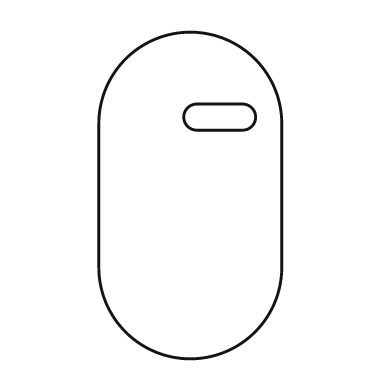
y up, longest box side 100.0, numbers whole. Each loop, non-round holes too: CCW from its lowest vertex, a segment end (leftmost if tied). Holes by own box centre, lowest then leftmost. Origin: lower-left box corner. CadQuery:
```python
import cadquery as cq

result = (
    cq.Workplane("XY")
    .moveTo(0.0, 28.0)
    .threePointArc((28.0, 0.0), (56.0, 28.0))
    .lineTo(56.0, 72.0)
    .threePointArc((28.0, 100.0), (0.0, 72.0))
    .close()
    .moveTo(30.0, 70.0)
    .lineTo(44.0, 70.0)
    .threePointArc((48.0, 74.0), (44.0, 78.0))
    .lineTo(30.0, 78.0)
    .threePointArc((26.0, 74.0), (30.0, 70.0))
    .close()
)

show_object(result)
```